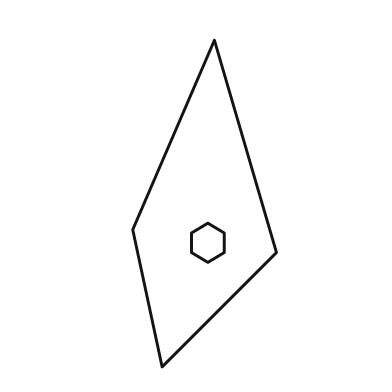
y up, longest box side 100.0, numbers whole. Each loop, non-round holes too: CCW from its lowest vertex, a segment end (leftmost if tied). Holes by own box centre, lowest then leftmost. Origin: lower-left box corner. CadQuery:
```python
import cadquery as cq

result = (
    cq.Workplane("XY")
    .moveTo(9.0, 0.0)
    .lineTo(44.0, 35.0)
    .lineTo(25.0, 100.0)
    .lineTo(0.0, 42.0)
    .close()
    .moveTo(23.0, 32.0)
    .lineTo(28.0, 35.0)
    .lineTo(28.0, 41.0)
    .lineTo(23.0, 44.0)
    .lineTo(18.0, 41.0)
    .lineTo(18.0, 35.0)
    .close()
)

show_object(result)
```